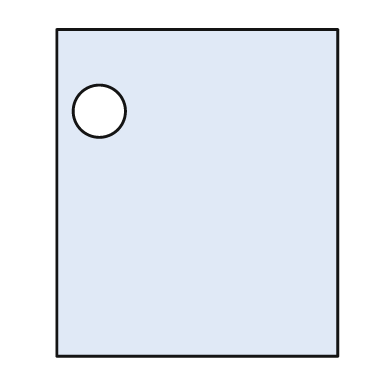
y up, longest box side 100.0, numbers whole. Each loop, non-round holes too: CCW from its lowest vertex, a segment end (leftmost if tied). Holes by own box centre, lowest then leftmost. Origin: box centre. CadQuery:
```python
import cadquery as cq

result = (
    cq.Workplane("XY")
    .moveTo(-43.0, -50.0)
    .lineTo(43.0, -50.0)
    .lineTo(43.0, 50.0)
    .lineTo(-43.0, 50.0)
    .close()
    .moveTo(-30.0, 25.0)
    .circle(8.0)
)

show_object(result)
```